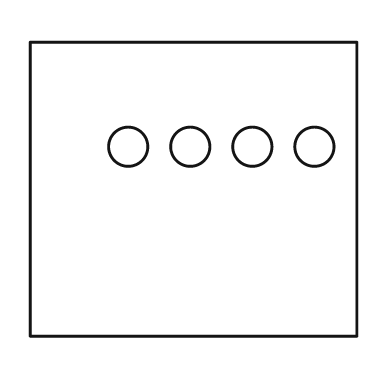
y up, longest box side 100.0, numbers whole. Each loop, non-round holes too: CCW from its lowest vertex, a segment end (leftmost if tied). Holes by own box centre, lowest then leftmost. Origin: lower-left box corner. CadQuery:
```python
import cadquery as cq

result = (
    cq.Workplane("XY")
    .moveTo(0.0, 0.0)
    .lineTo(100.0, 0.0)
    .lineTo(100.0, 90.0)
    .lineTo(0.0, 90.0)
    .close()
    .moveTo(30.0, 58.0)
    .circle(6.0)
    .moveTo(49.0, 58.0)
    .circle(6.0)
    .moveTo(68.0, 58.0)
    .circle(6.0)
    .moveTo(87.0, 58.0)
    .circle(6.0)
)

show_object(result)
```